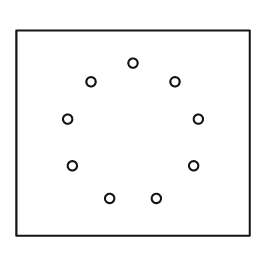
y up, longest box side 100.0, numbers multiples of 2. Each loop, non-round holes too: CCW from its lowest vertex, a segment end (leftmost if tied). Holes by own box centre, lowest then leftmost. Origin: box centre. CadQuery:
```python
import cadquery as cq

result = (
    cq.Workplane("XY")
    .moveTo(-50.0, -44.0)
    .lineTo(50.0, -44.0)
    .lineTo(50.0, 44.0)
    .lineTo(-50.0, 44.0)
    .close()
    .moveTo(-10.0, -28.0)
    .circle(2.0)
    .moveTo(10.0, -28.0)
    .circle(2.0)
    .moveTo(-26.0, -14.0)
    .circle(2.0)
    .moveTo(26.0, -14.0)
    .circle(2.0)
    .moveTo(-28.0, 6.0)
    .circle(2.0)
    .moveTo(28.0, 6.0)
    .circle(2.0)
    .moveTo(-18.0, 22.0)
    .circle(2.0)
    .moveTo(18.0, 22.0)
    .circle(2.0)
    .moveTo(0.0, 30.0)
    .circle(2.0)
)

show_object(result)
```